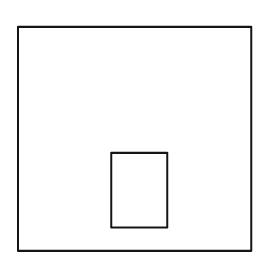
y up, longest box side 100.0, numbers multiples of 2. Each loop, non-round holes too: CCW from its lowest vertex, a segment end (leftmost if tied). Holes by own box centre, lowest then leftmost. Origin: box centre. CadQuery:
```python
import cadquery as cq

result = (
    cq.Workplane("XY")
    .moveTo(-50.0, -48.0)
    .lineTo(50.0, -48.0)
    .lineTo(50.0, 48.0)
    .lineTo(-50.0, 48.0)
    .close()
    .moveTo(-10.0, -38.0)
    .lineTo(14.0, -38.0)
    .lineTo(14.0, -6.0)
    .lineTo(-10.0, -6.0)
    .close()
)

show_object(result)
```